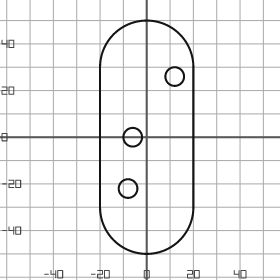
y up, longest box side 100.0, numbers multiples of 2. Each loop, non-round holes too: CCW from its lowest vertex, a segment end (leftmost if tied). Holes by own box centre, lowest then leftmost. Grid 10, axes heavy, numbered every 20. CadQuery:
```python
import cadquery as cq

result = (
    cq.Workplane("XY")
    .moveTo(-20.0, -30.0)
    .threePointArc((0.0, -50.0), (20.0, -30.0))
    .lineTo(20.0, 30.0)
    .threePointArc((0.0, 50.0), (-20.0, 30.0))
    .close()
    .moveTo(-8.0, -22.0)
    .circle(4.0)
    .moveTo(-6.0, 0.0)
    .circle(4.0)
    .moveTo(12.0, 26.0)
    .circle(4.0)
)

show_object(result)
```